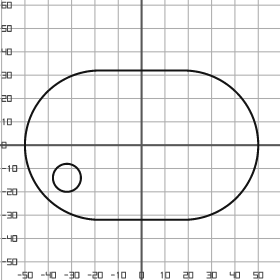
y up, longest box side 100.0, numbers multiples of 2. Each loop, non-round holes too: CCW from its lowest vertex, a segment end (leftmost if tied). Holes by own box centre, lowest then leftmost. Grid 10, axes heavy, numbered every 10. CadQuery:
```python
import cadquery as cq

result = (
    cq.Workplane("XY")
    .moveTo(-18.0, -32.0)
    .lineTo(18.0, -32.0)
    .threePointArc((50.0, 0.0), (18.0, 32.0))
    .lineTo(-18.0, 32.0)
    .threePointArc((-50.0, 0.0), (-18.0, -32.0))
    .close()
    .moveTo(-32.0, -14.0)
    .circle(6.0)
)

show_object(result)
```